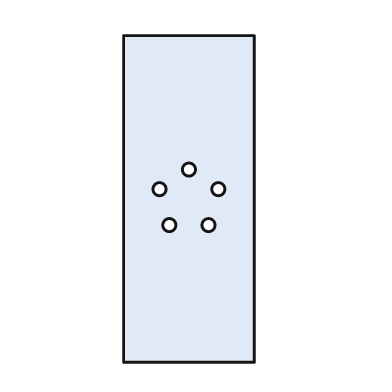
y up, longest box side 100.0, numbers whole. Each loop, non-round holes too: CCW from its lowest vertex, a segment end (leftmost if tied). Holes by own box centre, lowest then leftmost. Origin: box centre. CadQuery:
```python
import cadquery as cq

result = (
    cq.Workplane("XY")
    .moveTo(-20.0, -50.0)
    .lineTo(20.0, -50.0)
    .lineTo(20.0, 50.0)
    .lineTo(-20.0, 50.0)
    .close()
    .moveTo(-6.0, -8.0)
    .circle(2.0)
    .moveTo(6.0, -8.0)
    .circle(2.0)
    .moveTo(-9.0, 3.0)
    .circle(2.0)
    .moveTo(9.0, 3.0)
    .circle(2.0)
    .moveTo(0.0, 9.0)
    .circle(2.0)
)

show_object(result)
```